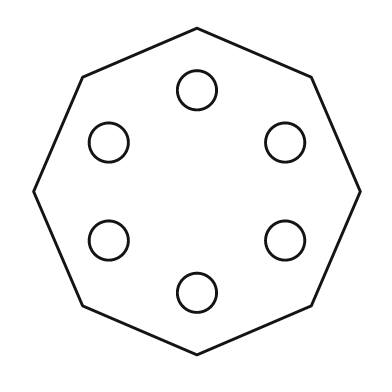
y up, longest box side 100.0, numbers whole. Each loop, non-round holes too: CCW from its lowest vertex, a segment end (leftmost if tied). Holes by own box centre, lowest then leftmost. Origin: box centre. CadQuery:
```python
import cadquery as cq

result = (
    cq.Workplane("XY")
    .moveTo(0.0, -50.0)
    .lineTo(35.0, -35.0)
    .lineTo(50.0, 0.0)
    .lineTo(35.0, 35.0)
    .lineTo(0.0, 50.0)
    .lineTo(-35.0, 35.0)
    .lineTo(-50.0, 0.0)
    .lineTo(-35.0, -35.0)
    .close()
    .moveTo(0.0, -31.0)
    .circle(6.0)
    .moveTo(-27.0, -15.0)
    .circle(6.0)
    .moveTo(27.0, -15.0)
    .circle(6.0)
    .moveTo(-27.0, 15.0)
    .circle(6.0)
    .moveTo(27.0, 15.0)
    .circle(6.0)
    .moveTo(0.0, 31.0)
    .circle(6.0)
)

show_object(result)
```